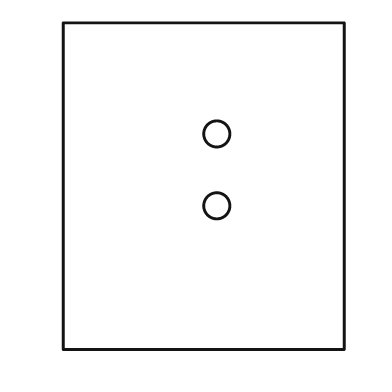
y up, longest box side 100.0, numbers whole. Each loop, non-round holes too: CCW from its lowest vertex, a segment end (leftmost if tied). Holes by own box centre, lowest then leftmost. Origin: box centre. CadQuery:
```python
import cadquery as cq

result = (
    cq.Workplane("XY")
    .moveTo(-43.0, -50.0)
    .lineTo(43.0, -50.0)
    .lineTo(43.0, 50.0)
    .lineTo(-43.0, 50.0)
    .close()
    .moveTo(4.0, -6.0)
    .circle(4.0)
    .moveTo(4.0, 16.0)
    .circle(4.0)
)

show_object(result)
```